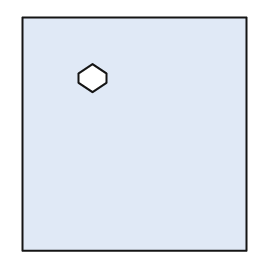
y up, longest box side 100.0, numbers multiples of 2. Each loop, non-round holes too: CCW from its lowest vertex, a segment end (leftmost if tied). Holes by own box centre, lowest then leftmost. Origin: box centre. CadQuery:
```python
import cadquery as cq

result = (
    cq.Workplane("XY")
    .moveTo(-48.0, -50.0)
    .lineTo(48.0, -50.0)
    .lineTo(48.0, 50.0)
    .lineTo(-48.0, 50.0)
    .close()
    .moveTo(-18.0, 18.0)
    .lineTo(-12.0, 22.0)
    .lineTo(-12.0, 26.0)
    .lineTo(-18.0, 30.0)
    .lineTo(-24.0, 26.0)
    .lineTo(-24.0, 22.0)
    .close()
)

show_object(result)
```